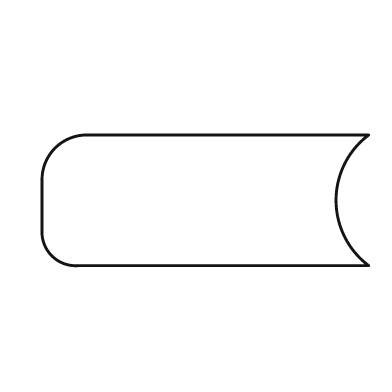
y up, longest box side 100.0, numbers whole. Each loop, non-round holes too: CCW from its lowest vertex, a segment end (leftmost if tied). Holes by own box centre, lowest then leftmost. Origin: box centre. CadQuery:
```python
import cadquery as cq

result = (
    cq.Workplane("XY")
    .moveTo(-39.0, -20.0)
    .lineTo(50.0, -20.0)
    .threePointArc((40.0, 0.0), (50.0, 20.0))
    .lineTo(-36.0, 20.0)
    .threePointArc((-46.0, 16.0), (-50.0, 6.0))
    .lineTo(-50.0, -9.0)
    .threePointArc((-47.0, -17.0), (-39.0, -20.0))
    .close()
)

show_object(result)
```